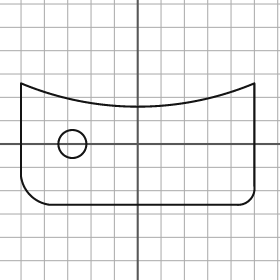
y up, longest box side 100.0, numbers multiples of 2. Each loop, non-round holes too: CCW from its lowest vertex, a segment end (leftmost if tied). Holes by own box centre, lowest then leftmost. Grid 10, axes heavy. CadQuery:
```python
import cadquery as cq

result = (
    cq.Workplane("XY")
    .moveTo(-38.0, -26.0)
    .lineTo(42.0, -26.0)
    .threePointArc((48.0, -24.0), (50.0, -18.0))
    .lineTo(50.0, 26.0)
    .threePointArc((0.0, 16.0), (-50.0, 26.0))
    .lineTo(-50.0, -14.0)
    .threePointArc((-46.0, -22.0), (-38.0, -26.0))
    .close()
    .moveTo(-28.0, 0.0)
    .circle(6.0)
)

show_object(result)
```